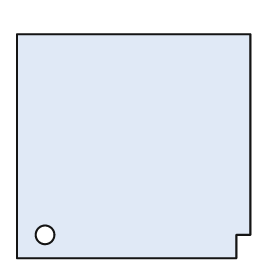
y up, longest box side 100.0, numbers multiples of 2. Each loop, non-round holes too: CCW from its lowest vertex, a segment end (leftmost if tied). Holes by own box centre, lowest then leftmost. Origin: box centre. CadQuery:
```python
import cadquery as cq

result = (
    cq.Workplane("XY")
    .moveTo(-50.0, -48.0)
    .lineTo(44.0, -48.0)
    .lineTo(44.0, -38.0)
    .lineTo(50.0, -38.0)
    .lineTo(50.0, 48.0)
    .lineTo(-50.0, 48.0)
    .close()
    .moveTo(-38.0, -38.0)
    .circle(4.0)
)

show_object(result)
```